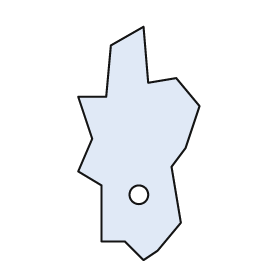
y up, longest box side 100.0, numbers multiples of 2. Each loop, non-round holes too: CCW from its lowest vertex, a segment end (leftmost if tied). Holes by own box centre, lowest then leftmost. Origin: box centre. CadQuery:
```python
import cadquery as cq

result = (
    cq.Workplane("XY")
    .moveTo(2.0, -50.0)
    .lineTo(8.0, -46.0)
    .lineTo(18.0, -34.0)
    .lineTo(14.0, -10.0)
    .lineTo(20.0, -2.0)
    .lineTo(26.0, 16.0)
    .lineTo(16.0, 28.0)
    .lineTo(4.0, 26.0)
    .lineTo(2.0, 50.0)
    .lineTo(-12.0, 42.0)
    .lineTo(-14.0, 20.0)
    .lineTo(-26.0, 20.0)
    .lineTo(-20.0, 2.0)
    .lineTo(-26.0, -12.0)
    .lineTo(-16.0, -18.0)
    .lineTo(-16.0, -42.0)
    .lineTo(-6.0, -42.0)
    .close()
    .moveTo(0.0, -22.0)
    .circle(4.0)
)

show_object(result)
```